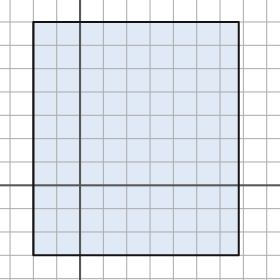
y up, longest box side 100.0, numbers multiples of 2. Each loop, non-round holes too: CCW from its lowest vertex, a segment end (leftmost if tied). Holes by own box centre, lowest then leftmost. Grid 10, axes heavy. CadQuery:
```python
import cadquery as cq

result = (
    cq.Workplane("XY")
    .moveTo(-20.0, -30.0)
    .lineTo(68.0, -30.0)
    .lineTo(68.0, 70.0)
    .lineTo(-20.0, 70.0)
    .close()
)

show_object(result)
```